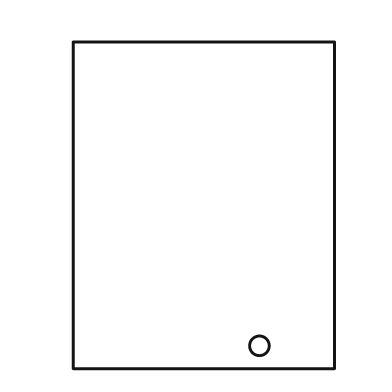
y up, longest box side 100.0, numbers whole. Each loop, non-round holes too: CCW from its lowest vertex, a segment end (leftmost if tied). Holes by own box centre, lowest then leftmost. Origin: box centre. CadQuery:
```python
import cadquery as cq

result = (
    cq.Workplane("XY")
    .moveTo(-40.0, -50.0)
    .lineTo(40.0, -50.0)
    .lineTo(40.0, 50.0)
    .lineTo(-40.0, 50.0)
    .close()
    .moveTo(17.0, -43.0)
    .circle(3.0)
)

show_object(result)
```